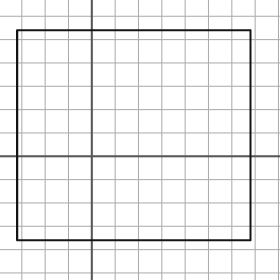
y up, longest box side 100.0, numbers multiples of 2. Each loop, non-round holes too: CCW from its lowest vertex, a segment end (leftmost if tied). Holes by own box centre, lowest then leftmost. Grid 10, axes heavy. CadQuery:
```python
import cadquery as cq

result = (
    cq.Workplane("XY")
    .moveTo(-32.0, -36.0)
    .lineTo(68.0, -36.0)
    .lineTo(68.0, 54.0)
    .lineTo(-32.0, 54.0)
    .close()
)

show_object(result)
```